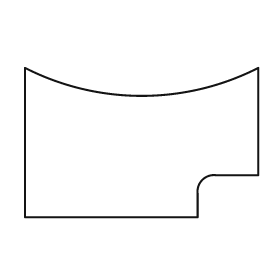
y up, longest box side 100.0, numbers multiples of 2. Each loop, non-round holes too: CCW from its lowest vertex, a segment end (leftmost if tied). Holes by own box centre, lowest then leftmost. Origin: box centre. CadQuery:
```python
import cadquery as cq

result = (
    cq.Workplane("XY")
    .moveTo(-50.0, -32.0)
    .lineTo(24.0, -32.0)
    .lineTo(24.0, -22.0)
    .threePointArc((26.0, -16.0), (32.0, -14.0))
    .lineTo(50.0, -14.0)
    .lineTo(50.0, 32.0)
    .threePointArc((0.0, 20.0), (-50.0, 32.0))
    .close()
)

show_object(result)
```